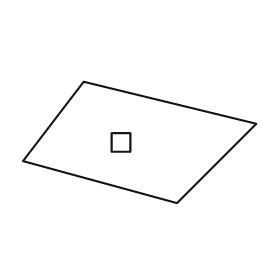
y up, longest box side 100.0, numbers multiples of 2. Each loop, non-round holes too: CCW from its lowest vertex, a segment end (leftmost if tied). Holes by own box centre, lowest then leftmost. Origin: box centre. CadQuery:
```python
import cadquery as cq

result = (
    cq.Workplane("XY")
    .moveTo(16.0, -26.0)
    .lineTo(50.0, 8.0)
    .lineTo(-24.0, 26.0)
    .lineTo(-50.0, -8.0)
    .close()
    .moveTo(-12.0, -4.0)
    .lineTo(-4.0, -4.0)
    .lineTo(-4.0, 4.0)
    .lineTo(-12.0, 4.0)
    .close()
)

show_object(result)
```